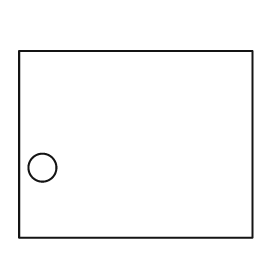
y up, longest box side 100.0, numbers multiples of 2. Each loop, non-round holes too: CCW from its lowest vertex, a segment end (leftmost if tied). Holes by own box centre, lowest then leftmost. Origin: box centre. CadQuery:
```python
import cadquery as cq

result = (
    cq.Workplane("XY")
    .moveTo(-50.0, -40.0)
    .lineTo(50.0, -40.0)
    .lineTo(50.0, 40.0)
    .lineTo(-50.0, 40.0)
    .close()
    .moveTo(-40.0, -10.0)
    .circle(6.0)
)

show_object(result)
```